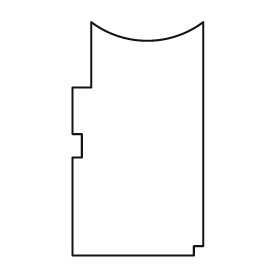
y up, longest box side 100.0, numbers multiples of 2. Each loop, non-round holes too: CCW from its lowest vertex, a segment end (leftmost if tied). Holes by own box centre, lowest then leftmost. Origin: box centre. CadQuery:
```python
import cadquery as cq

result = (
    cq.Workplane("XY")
    .moveTo(-28.0, -50.0)
    .lineTo(24.0, -50.0)
    .lineTo(24.0, -46.0)
    .lineTo(28.0, -46.0)
    .lineTo(28.0, 50.0)
    .threePointArc((4.0, 42.0), (-20.0, 50.0))
    .lineTo(-20.0, 22.0)
    .lineTo(-28.0, 22.0)
    .lineTo(-28.0, 2.0)
    .lineTo(-24.0, 2.0)
    .lineTo(-24.0, -8.0)
    .lineTo(-28.0, -8.0)
    .close()
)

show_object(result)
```